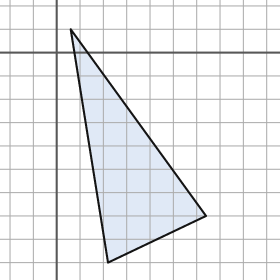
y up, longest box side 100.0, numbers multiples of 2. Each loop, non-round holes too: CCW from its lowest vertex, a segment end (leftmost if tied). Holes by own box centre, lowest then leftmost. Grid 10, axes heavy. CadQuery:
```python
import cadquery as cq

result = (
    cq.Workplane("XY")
    .moveTo(22.0, -90.0)
    .lineTo(64.0, -70.0)
    .lineTo(6.0, 10.0)
    .close()
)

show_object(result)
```